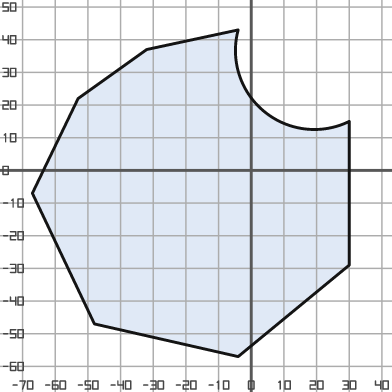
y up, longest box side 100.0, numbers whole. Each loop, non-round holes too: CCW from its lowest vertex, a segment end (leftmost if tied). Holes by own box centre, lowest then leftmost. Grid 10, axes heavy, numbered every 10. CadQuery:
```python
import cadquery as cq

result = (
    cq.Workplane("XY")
    .moveTo(-4.0, -57.0)
    .lineTo(30.0, -29.0)
    .lineTo(30.0, 15.0)
    .threePointArc((4.0, 18.0), (-4.0, 43.0))
    .lineTo(-32.0, 37.0)
    .lineTo(-53.0, 22.0)
    .lineTo(-67.0, -7.0)
    .lineTo(-48.0, -47.0)
    .close()
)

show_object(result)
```